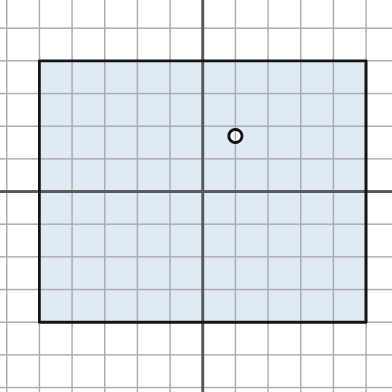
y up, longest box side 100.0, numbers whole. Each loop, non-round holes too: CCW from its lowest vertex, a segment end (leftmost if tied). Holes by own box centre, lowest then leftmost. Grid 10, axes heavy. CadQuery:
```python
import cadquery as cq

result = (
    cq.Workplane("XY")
    .moveTo(-50.0, -40.0)
    .lineTo(50.0, -40.0)
    .lineTo(50.0, 40.0)
    .lineTo(-50.0, 40.0)
    .close()
    .moveTo(10.0, 17.0)
    .circle(2.0)
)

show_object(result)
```